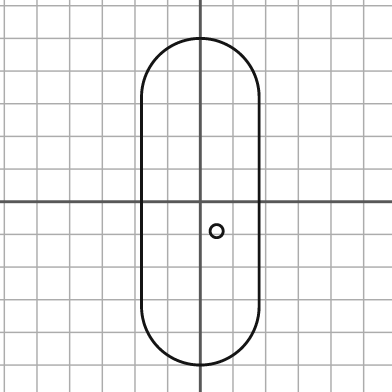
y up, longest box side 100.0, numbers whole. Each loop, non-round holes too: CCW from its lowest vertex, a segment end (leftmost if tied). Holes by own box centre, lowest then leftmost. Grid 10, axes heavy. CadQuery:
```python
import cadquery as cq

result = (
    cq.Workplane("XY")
    .moveTo(-18.0, -32.0)
    .threePointArc((0.0, -50.0), (18.0, -32.0))
    .lineTo(18.0, 32.0)
    .threePointArc((0.0, 50.0), (-18.0, 32.0))
    .close()
    .moveTo(5.0, -9.0)
    .circle(2.0)
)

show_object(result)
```